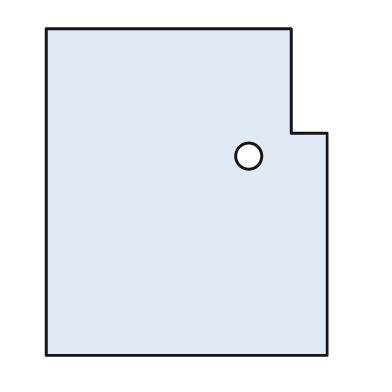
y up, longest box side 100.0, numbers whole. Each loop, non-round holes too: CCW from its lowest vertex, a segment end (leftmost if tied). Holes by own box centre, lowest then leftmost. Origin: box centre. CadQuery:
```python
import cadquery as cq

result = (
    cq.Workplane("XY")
    .moveTo(-43.0, -50.0)
    .lineTo(43.0, -50.0)
    .lineTo(43.0, 18.0)
    .lineTo(32.0, 18.0)
    .lineTo(32.0, 50.0)
    .lineTo(-43.0, 50.0)
    .close()
    .moveTo(19.0, 11.0)
    .circle(4.0)
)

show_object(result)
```